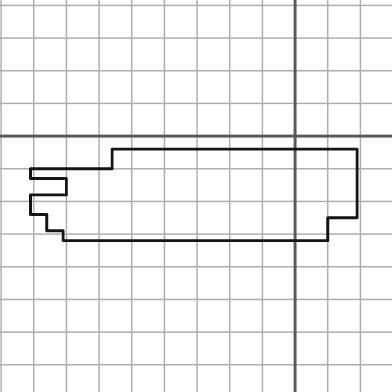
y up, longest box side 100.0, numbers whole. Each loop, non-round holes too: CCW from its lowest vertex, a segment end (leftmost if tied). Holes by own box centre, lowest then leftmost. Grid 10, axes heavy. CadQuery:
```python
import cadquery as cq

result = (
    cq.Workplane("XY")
    .moveTo(-71.0, -32.0)
    .lineTo(10.0, -32.0)
    .lineTo(10.0, -25.0)
    .lineTo(19.0, -25.0)
    .lineTo(19.0, -4.0)
    .lineTo(-56.0, -4.0)
    .lineTo(-56.0, -10.0)
    .lineTo(-81.0, -10.0)
    .lineTo(-81.0, -13.0)
    .lineTo(-70.0, -13.0)
    .lineTo(-70.0, -18.0)
    .lineTo(-81.0, -18.0)
    .lineTo(-81.0, -24.0)
    .lineTo(-76.0, -24.0)
    .lineTo(-76.0, -29.0)
    .lineTo(-71.0, -29.0)
    .close()
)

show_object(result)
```